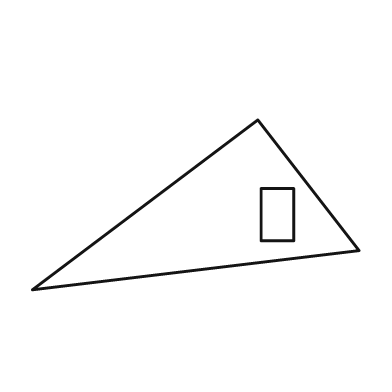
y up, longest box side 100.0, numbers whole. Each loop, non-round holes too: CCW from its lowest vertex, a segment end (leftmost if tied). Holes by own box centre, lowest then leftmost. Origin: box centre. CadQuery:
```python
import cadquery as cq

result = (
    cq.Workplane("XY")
    .moveTo(-50.0, -26.0)
    .lineTo(50.0, -14.0)
    .lineTo(19.0, 26.0)
    .close()
    .moveTo(20.0, -11.0)
    .lineTo(30.0, -11.0)
    .lineTo(30.0, 5.0)
    .lineTo(20.0, 5.0)
    .close()
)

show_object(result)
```